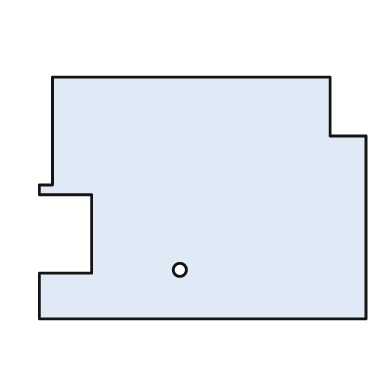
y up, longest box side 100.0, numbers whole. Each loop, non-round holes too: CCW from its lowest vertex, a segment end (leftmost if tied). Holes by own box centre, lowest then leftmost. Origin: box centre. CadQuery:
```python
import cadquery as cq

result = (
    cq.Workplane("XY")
    .moveTo(-50.0, -37.0)
    .lineTo(50.0, -37.0)
    .lineTo(50.0, 19.0)
    .lineTo(39.0, 19.0)
    .lineTo(39.0, 37.0)
    .lineTo(-46.0, 37.0)
    .lineTo(-46.0, 4.0)
    .lineTo(-50.0, 4.0)
    .lineTo(-50.0, 1.0)
    .lineTo(-34.0, 1.0)
    .lineTo(-34.0, -23.0)
    .lineTo(-50.0, -23.0)
    .close()
    .moveTo(-7.0, -22.0)
    .circle(2.0)
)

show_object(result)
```